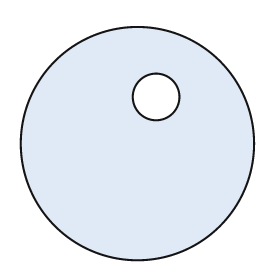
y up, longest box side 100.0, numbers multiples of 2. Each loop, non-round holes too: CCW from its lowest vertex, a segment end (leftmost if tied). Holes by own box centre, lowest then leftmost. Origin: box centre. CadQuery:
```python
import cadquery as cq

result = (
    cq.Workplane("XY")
    .moveTo(0.0, 0.0)
    .circle(50.0)
    .moveTo(8.0, 20.0)
    .circle(10.0)
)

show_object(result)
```